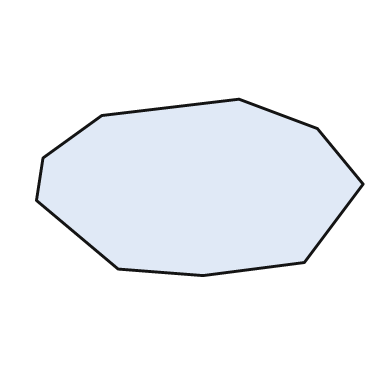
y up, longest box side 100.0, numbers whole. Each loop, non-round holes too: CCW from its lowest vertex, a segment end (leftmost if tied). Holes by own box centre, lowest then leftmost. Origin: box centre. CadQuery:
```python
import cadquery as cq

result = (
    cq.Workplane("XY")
    .moveTo(1.0, -27.0)
    .lineTo(32.0, -23.0)
    .lineTo(50.0, 1.0)
    .lineTo(36.0, 18.0)
    .lineTo(12.0, 27.0)
    .lineTo(-30.0, 22.0)
    .lineTo(-48.0, 9.0)
    .lineTo(-50.0, -4.0)
    .lineTo(-25.0, -25.0)
    .close()
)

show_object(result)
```